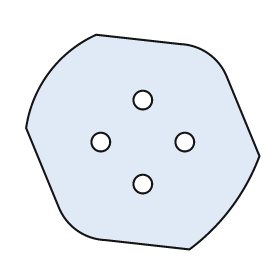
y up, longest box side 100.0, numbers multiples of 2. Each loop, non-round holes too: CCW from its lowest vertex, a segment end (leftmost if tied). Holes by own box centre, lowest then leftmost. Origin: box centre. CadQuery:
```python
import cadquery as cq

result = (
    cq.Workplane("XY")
    .moveTo(20.0, -46.0)
    .threePointArc((38.0, -28.0), (50.0, -6.0))
    .lineTo(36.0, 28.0)
    .threePointArc((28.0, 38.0), (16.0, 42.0))
    .lineTo(-20.0, 46.0)
    .threePointArc((-40.0, 30.0), (-50.0, 6.0))
    .lineTo(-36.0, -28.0)
    .threePointArc((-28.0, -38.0), (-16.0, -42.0))
    .close()
    .moveTo(0.0, -18.0)
    .circle(4.0)
    .moveTo(-18.0, 0.0)
    .circle(4.0)
    .moveTo(18.0, 0.0)
    .circle(4.0)
    .moveTo(0.0, 18.0)
    .circle(4.0)
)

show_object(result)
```